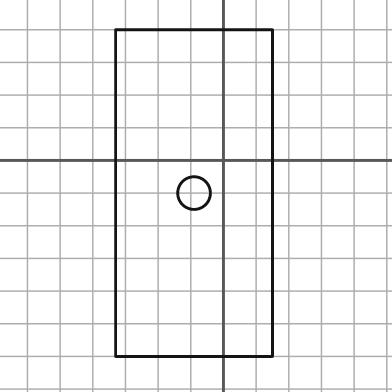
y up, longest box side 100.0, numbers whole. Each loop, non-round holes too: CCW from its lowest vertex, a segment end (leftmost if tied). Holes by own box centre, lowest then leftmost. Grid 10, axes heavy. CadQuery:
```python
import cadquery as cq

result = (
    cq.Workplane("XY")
    .moveTo(-33.0, -60.0)
    .lineTo(15.0, -60.0)
    .lineTo(15.0, 40.0)
    .lineTo(-33.0, 40.0)
    .close()
    .moveTo(-9.0, -10.0)
    .circle(5.0)
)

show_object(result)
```